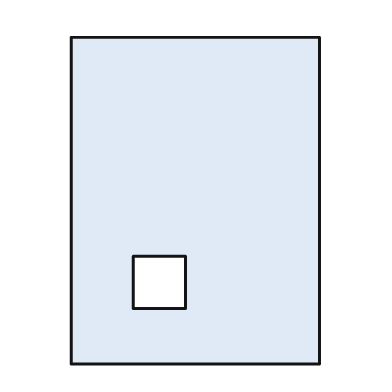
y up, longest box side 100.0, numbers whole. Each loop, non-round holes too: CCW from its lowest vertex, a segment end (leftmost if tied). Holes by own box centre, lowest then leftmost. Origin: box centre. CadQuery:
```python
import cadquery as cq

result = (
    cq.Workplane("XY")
    .moveTo(-38.0, -50.0)
    .lineTo(38.0, -50.0)
    .lineTo(38.0, 50.0)
    .lineTo(-38.0, 50.0)
    .close()
    .moveTo(-19.0, -33.0)
    .lineTo(-3.0, -33.0)
    .lineTo(-3.0, -17.0)
    .lineTo(-19.0, -17.0)
    .close()
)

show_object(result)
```